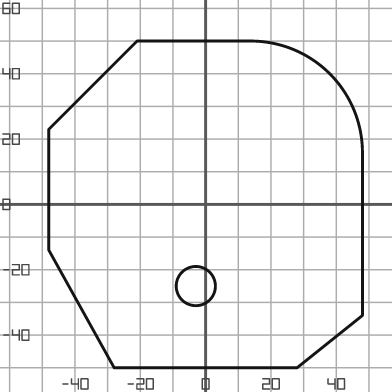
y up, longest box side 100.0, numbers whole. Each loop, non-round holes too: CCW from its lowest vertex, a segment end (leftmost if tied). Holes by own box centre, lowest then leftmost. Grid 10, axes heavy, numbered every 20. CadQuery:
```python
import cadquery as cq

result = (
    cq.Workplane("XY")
    .moveTo(-28.0, -50.0)
    .lineTo(28.0, -50.0)
    .lineTo(48.0, -34.0)
    .lineTo(48.0, 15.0)
    .threePointArc((38.0, 40.0), (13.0, 50.0))
    .lineTo(-21.0, 50.0)
    .lineTo(-48.0, 23.0)
    .lineTo(-48.0, -14.0)
    .close()
    .moveTo(-3.0, -25.0)
    .circle(6.0)
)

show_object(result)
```